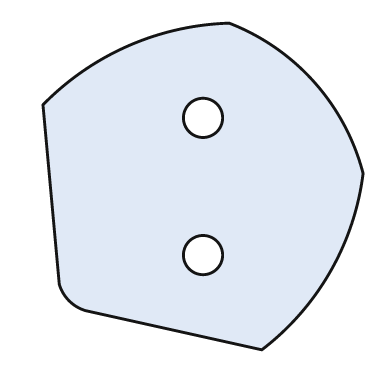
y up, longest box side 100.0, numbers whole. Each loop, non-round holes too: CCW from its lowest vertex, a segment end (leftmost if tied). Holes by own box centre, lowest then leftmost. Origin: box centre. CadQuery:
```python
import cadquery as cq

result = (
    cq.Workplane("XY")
    .moveTo(18.0, -50.0)
    .threePointArc((39.0, -26.0), (49.0, 4.0))
    .threePointArc((34.0, 32.0), (8.0, 50.0))
    .threePointArc((-23.0, 43.0), (-49.0, 25.0))
    .lineTo(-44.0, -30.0)
    .threePointArc((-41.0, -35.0), (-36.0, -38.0))
    .close()
    .moveTo(0.0, -21.0)
    .circle(6.0)
    .moveTo(0.0, 21.0)
    .circle(6.0)
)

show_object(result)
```